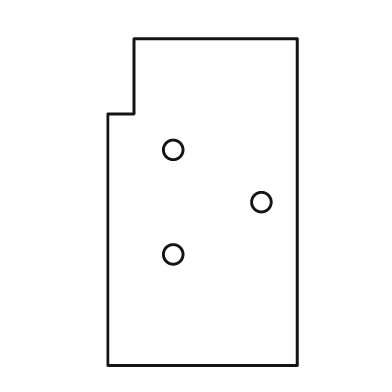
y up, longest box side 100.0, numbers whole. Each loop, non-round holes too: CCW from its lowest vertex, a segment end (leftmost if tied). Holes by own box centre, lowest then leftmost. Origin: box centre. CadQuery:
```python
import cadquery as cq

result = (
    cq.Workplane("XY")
    .moveTo(-29.0, -50.0)
    .lineTo(29.0, -50.0)
    .lineTo(29.0, 50.0)
    .lineTo(-21.0, 50.0)
    .lineTo(-21.0, 27.0)
    .lineTo(-29.0, 27.0)
    .close()
    .moveTo(-9.0, -16.0)
    .circle(3.0)
    .moveTo(18.0, 0.0)
    .circle(3.0)
    .moveTo(-9.0, 16.0)
    .circle(3.0)
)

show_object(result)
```